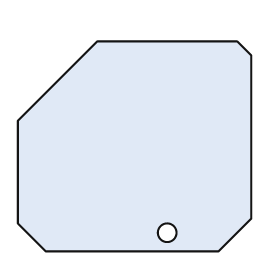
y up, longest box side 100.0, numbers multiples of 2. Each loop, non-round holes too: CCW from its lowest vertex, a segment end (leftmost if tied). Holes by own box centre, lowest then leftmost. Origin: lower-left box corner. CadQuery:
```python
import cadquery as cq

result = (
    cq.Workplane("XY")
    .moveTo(12.0, 0.0)
    .lineTo(86.0, 0.0)
    .lineTo(100.0, 14.0)
    .lineTo(100.0, 84.0)
    .lineTo(94.0, 90.0)
    .lineTo(34.0, 90.0)
    .lineTo(0.0, 56.0)
    .lineTo(0.0, 12.0)
    .close()
    .moveTo(64.0, 8.0)
    .circle(4.0)
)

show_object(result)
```